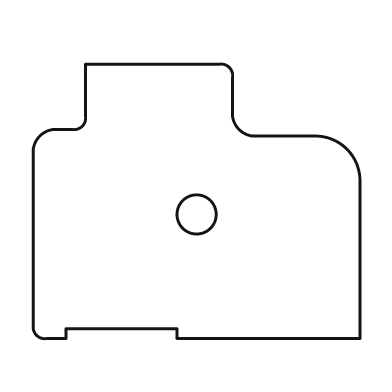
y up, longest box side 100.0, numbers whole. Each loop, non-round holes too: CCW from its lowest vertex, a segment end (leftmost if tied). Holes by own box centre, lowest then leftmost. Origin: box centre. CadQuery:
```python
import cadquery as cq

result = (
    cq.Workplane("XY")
    .moveTo(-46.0, -42.0)
    .lineTo(-40.0, -42.0)
    .lineTo(-40.0, -39.0)
    .lineTo(-6.0, -39.0)
    .lineTo(-6.0, -42.0)
    .lineTo(50.0, -42.0)
    .lineTo(50.0, 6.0)
    .threePointArc((46.0, 16.0), (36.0, 20.0))
    .lineTo(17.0, 20.0)
    .threePointArc((13.0, 22.0), (11.0, 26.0))
    .lineTo(11.0, 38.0)
    .threePointArc((10.0, 41.0), (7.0, 42.0))
    .lineTo(-34.0, 42.0)
    .lineTo(-34.0, 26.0)
    .threePointArc((-35.0, 23.0), (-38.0, 22.0))
    .lineTo(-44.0, 22.0)
    .threePointArc((-48.0, 20.0), (-50.0, 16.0))
    .lineTo(-50.0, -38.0)
    .threePointArc((-49.0, -41.0), (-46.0, -42.0))
    .close()
    .moveTo(0.0, -4.0)
    .circle(6.0)
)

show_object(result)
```